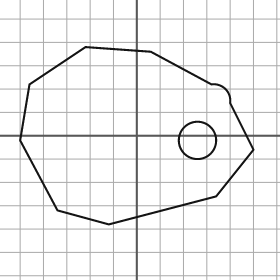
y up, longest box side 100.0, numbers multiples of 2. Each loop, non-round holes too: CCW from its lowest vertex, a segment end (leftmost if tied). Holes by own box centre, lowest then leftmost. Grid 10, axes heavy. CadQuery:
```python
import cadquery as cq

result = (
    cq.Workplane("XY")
    .moveTo(-12.0, -38.0)
    .lineTo(34.0, -26.0)
    .lineTo(50.0, -6.0)
    .lineTo(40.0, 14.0)
    .threePointArc((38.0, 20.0), (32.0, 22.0))
    .lineTo(6.0, 36.0)
    .lineTo(-22.0, 38.0)
    .lineTo(-46.0, 22.0)
    .lineTo(-50.0, -2.0)
    .lineTo(-34.0, -32.0)
    .close()
    .moveTo(26.0, -2.0)
    .circle(8.0)
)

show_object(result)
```